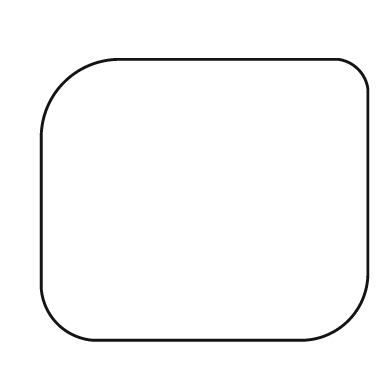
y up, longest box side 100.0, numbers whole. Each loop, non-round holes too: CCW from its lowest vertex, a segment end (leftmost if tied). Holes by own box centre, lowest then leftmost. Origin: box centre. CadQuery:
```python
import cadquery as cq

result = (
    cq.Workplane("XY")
    .moveTo(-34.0, -43.0)
    .lineTo(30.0, -43.0)
    .threePointArc((44.0, -37.0), (50.0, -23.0))
    .lineTo(50.0, 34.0)
    .threePointArc((47.0, 40.0), (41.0, 43.0))
    .lineTo(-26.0, 43.0)
    .threePointArc((-43.0, 36.0), (-50.0, 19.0))
    .lineTo(-50.0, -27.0)
    .threePointArc((-45.0, -38.0), (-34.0, -43.0))
    .close()
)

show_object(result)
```